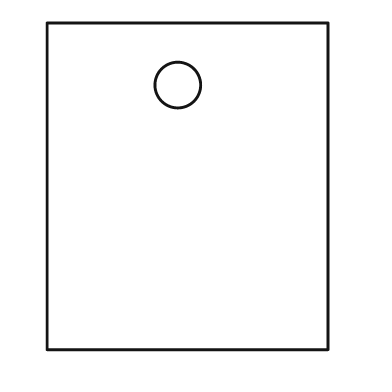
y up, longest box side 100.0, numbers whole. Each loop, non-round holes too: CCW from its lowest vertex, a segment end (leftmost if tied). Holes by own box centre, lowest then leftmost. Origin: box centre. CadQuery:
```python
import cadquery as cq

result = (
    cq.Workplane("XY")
    .moveTo(-43.0, -50.0)
    .lineTo(43.0, -50.0)
    .lineTo(43.0, 50.0)
    .lineTo(-43.0, 50.0)
    .close()
    .moveTo(-3.0, 31.0)
    .circle(7.0)
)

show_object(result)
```